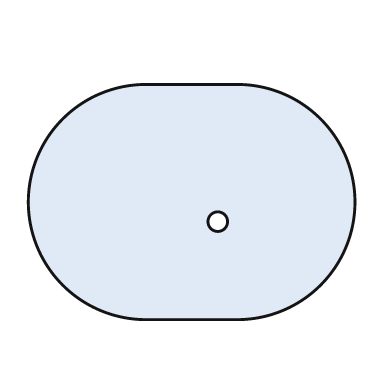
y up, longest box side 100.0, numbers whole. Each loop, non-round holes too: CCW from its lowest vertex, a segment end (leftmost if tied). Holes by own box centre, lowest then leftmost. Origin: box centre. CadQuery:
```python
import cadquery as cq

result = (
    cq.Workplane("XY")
    .moveTo(-14.0, -36.0)
    .lineTo(14.0, -36.0)
    .threePointArc((50.0, 0.0), (14.0, 36.0))
    .lineTo(-14.0, 36.0)
    .threePointArc((-50.0, 0.0), (-14.0, -36.0))
    .close()
    .moveTo(8.0, -6.0)
    .circle(3.0)
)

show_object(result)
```